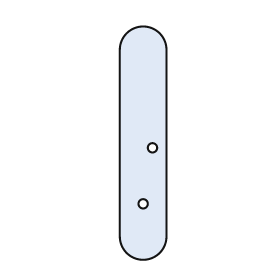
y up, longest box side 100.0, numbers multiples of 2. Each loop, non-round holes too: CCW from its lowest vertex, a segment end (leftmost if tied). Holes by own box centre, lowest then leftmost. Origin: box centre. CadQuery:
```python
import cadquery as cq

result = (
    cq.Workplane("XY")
    .moveTo(-10.0, -40.0)
    .threePointArc((0.0, -50.0), (10.0, -40.0))
    .lineTo(10.0, 40.0)
    .threePointArc((0.0, 50.0), (-10.0, 40.0))
    .close()
    .moveTo(0.0, -26.0)
    .circle(2.0)
    .moveTo(4.0, -2.0)
    .circle(2.0)
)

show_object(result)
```